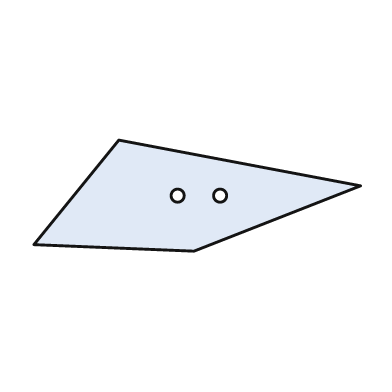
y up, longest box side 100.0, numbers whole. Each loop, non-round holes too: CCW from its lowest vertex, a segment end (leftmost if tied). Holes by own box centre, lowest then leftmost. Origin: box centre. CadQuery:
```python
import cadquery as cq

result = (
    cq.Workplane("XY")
    .moveTo(-1.0, -17.0)
    .lineTo(50.0, 3.0)
    .lineTo(-24.0, 17.0)
    .lineTo(-50.0, -15.0)
    .close()
    .moveTo(-6.0, 0.0)
    .circle(2.0)
    .moveTo(7.0, 0.0)
    .circle(2.0)
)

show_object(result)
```